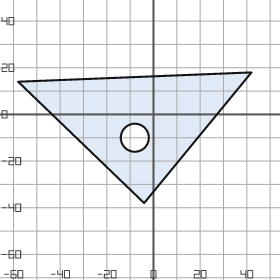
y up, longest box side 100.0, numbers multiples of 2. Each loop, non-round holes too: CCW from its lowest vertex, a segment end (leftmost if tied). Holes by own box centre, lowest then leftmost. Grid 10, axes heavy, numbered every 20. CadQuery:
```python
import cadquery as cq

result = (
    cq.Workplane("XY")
    .moveTo(-4.0, -38.0)
    .lineTo(42.0, 18.0)
    .lineTo(-58.0, 14.0)
    .close()
    .moveTo(-8.0, -10.0)
    .circle(6.0)
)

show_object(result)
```